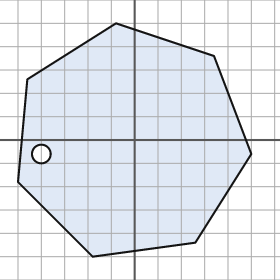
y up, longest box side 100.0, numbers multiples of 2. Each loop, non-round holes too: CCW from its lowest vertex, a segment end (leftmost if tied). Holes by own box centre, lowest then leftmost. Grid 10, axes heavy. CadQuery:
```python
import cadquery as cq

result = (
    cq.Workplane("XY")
    .moveTo(-18.0, -50.0)
    .lineTo(26.0, -44.0)
    .lineTo(50.0, -6.0)
    .lineTo(34.0, 36.0)
    .lineTo(-8.0, 50.0)
    .lineTo(-46.0, 26.0)
    .lineTo(-50.0, -18.0)
    .close()
    .moveTo(-40.0, -6.0)
    .circle(4.0)
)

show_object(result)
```